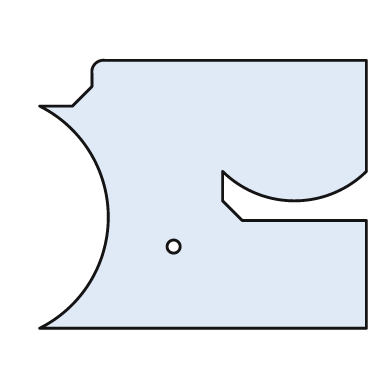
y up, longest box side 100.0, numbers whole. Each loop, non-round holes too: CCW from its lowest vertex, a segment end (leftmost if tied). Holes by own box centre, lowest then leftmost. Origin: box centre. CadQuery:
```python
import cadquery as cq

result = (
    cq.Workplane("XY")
    .moveTo(-50.0, -41.0)
    .lineTo(50.0, -41.0)
    .lineTo(50.0, -8.0)
    .lineTo(12.0, -8.0)
    .lineTo(6.0, -2.0)
    .lineTo(6.0, 7.0)
    .threePointArc((28.0, -2.0), (50.0, 7.0))
    .lineTo(50.0, 41.0)
    .lineTo(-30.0, 41.0)
    .threePointArc((-33.0, 40.0), (-34.0, 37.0))
    .lineTo(-34.0, 33.0)
    .lineTo(-40.0, 27.0)
    .lineTo(-50.0, 27.0)
    .threePointArc((-29.0, -7.0), (-50.0, -41.0))
    .close()
    .moveTo(-9.0, -16.0)
    .circle(2.0)
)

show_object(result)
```